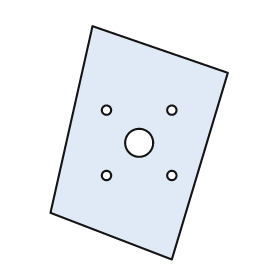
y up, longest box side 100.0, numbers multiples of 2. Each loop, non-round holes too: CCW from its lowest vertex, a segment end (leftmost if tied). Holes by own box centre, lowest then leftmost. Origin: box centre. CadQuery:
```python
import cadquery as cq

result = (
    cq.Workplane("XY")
    .moveTo(14.0, -50.0)
    .lineTo(38.0, 30.0)
    .lineTo(-20.0, 50.0)
    .lineTo(-38.0, -30.0)
    .close()
    .moveTo(-14.0, -14.0)
    .circle(2.0)
    .moveTo(14.0, -14.0)
    .circle(2.0)
    .moveTo(0.0, 0.0)
    .circle(6.0)
    .moveTo(-14.0, 14.0)
    .circle(2.0)
    .moveTo(14.0, 14.0)
    .circle(2.0)
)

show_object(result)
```